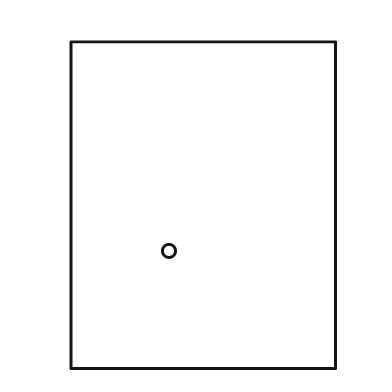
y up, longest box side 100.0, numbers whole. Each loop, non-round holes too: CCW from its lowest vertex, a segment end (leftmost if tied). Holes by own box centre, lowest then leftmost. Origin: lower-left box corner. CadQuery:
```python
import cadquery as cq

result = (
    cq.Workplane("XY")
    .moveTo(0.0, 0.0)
    .lineTo(81.0, 0.0)
    .lineTo(81.0, 100.0)
    .lineTo(0.0, 100.0)
    .close()
    .moveTo(30.0, 36.0)
    .circle(2.0)
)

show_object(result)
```